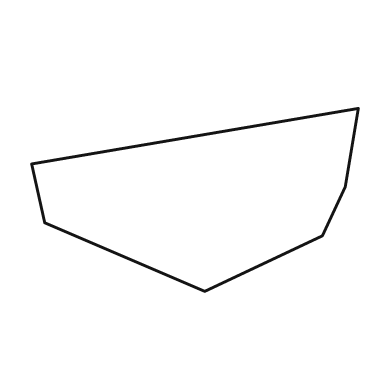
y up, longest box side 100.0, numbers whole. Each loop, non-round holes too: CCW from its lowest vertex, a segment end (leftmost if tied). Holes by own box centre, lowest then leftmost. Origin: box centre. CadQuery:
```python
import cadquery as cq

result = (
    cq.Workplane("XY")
    .moveTo(3.0, -28.0)
    .lineTo(39.0, -11.0)
    .lineTo(46.0, 4.0)
    .lineTo(50.0, 28.0)
    .lineTo(-50.0, 11.0)
    .lineTo(-46.0, -7.0)
    .close()
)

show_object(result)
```